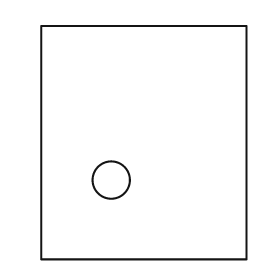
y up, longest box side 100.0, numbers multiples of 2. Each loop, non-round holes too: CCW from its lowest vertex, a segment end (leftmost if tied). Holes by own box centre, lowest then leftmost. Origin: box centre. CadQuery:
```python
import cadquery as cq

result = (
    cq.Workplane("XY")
    .moveTo(-44.0, -50.0)
    .lineTo(44.0, -50.0)
    .lineTo(44.0, 50.0)
    .lineTo(-44.0, 50.0)
    .close()
    .moveTo(-14.0, -16.0)
    .circle(8.0)
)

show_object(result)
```